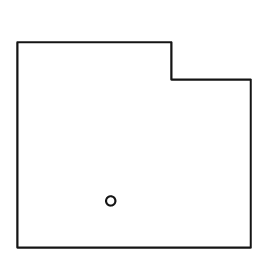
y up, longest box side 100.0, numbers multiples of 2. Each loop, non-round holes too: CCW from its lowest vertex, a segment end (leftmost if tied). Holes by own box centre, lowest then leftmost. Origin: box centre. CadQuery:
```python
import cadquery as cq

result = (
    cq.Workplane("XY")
    .moveTo(-50.0, -44.0)
    .lineTo(50.0, -44.0)
    .lineTo(50.0, 28.0)
    .lineTo(16.0, 28.0)
    .lineTo(16.0, 44.0)
    .lineTo(-50.0, 44.0)
    .close()
    .moveTo(-10.0, -24.0)
    .circle(2.0)
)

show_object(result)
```